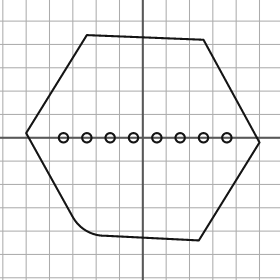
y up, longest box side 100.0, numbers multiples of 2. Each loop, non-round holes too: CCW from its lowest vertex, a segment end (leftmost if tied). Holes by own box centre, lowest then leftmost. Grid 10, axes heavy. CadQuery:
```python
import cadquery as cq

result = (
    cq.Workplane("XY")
    .moveTo(24.0, -44.0)
    .lineTo(50.0, -2.0)
    .lineTo(26.0, 42.0)
    .lineTo(-24.0, 44.0)
    .lineTo(-50.0, 2.0)
    .lineTo(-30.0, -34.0)
    .threePointArc((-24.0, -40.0), (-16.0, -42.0))
    .close()
    .moveTo(-34.0, 0.0)
    .circle(2.0)
    .moveTo(-24.0, 0.0)
    .circle(2.0)
    .moveTo(-14.0, 0.0)
    .circle(2.0)
    .moveTo(-4.0, 0.0)
    .circle(2.0)
    .moveTo(6.0, 0.0)
    .circle(2.0)
    .moveTo(16.0, 0.0)
    .circle(2.0)
    .moveTo(26.0, 0.0)
    .circle(2.0)
    .moveTo(36.0, 0.0)
    .circle(2.0)
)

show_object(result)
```